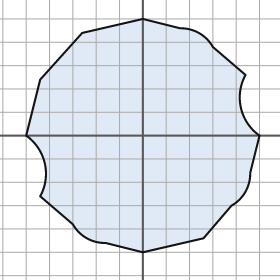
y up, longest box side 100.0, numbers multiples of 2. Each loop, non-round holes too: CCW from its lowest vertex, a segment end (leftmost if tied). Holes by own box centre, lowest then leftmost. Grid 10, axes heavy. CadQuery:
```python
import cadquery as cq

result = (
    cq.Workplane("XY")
    .moveTo(0.0, -50.0)
    .lineTo(26.0, -44.0)
    .lineTo(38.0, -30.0)
    .threePointArc((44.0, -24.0), (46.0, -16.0))
    .lineTo(50.0, 0.0)
    .threePointArc((42.0, 12.0), (44.0, 26.0))
    .lineTo(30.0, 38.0)
    .threePointArc((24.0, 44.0), (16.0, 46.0))
    .lineTo(0.0, 50.0)
    .lineTo(-26.0, 44.0)
    .lineTo(-44.0, 24.0)
    .lineTo(-50.0, 0.0)
    .threePointArc((-42.0, -12.0), (-44.0, -26.0))
    .lineTo(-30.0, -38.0)
    .threePointArc((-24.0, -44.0), (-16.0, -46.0))
    .close()
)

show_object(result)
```